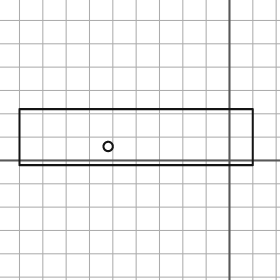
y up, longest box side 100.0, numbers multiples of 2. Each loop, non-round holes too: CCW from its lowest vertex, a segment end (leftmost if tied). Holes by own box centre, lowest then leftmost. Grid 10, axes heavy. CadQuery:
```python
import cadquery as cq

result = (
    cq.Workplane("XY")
    .moveTo(-90.0, -2.0)
    .lineTo(10.0, -2.0)
    .lineTo(10.0, 22.0)
    .lineTo(-90.0, 22.0)
    .close()
    .moveTo(-52.0, 6.0)
    .circle(2.0)
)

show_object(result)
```